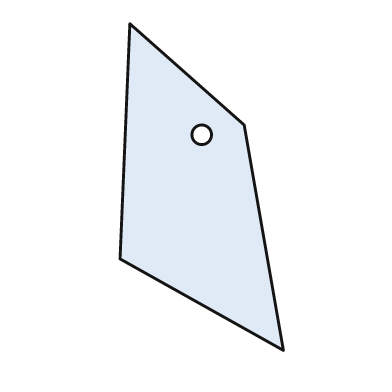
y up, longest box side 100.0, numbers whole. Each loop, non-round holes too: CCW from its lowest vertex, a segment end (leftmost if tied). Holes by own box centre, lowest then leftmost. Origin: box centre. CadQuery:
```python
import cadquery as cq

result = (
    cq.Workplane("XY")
    .moveTo(25.0, -50.0)
    .lineTo(13.0, 19.0)
    .lineTo(-22.0, 50.0)
    .lineTo(-25.0, -22.0)
    .close()
    .moveTo(0.0, 16.0)
    .circle(3.0)
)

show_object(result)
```